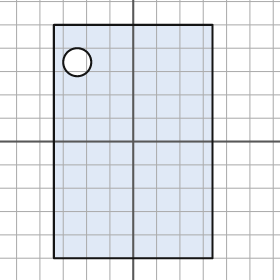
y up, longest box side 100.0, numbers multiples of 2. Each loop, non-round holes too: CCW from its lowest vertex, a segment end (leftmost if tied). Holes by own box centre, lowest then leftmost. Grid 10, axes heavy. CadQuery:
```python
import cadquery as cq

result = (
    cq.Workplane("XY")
    .moveTo(-34.0, -50.0)
    .lineTo(34.0, -50.0)
    .lineTo(34.0, 50.0)
    .lineTo(-34.0, 50.0)
    .close()
    .moveTo(-24.0, 34.0)
    .circle(6.0)
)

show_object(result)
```